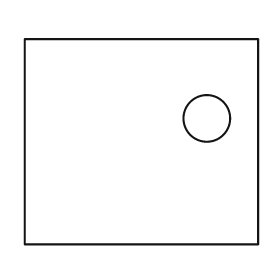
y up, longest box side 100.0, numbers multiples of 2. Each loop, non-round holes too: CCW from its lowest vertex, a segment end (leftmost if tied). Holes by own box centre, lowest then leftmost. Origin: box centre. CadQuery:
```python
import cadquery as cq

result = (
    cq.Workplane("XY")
    .moveTo(-50.0, -44.0)
    .lineTo(50.0, -44.0)
    .lineTo(50.0, 44.0)
    .lineTo(-50.0, 44.0)
    .close()
    .moveTo(28.0, 10.0)
    .circle(10.0)
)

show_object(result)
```